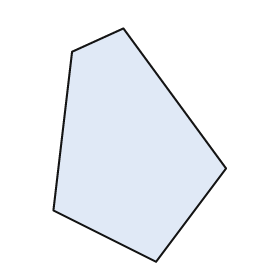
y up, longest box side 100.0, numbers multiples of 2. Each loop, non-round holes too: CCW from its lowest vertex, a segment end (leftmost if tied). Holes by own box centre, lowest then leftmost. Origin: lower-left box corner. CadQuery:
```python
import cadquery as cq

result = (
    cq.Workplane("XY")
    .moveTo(44.0, 0.0)
    .lineTo(74.0, 40.0)
    .lineTo(30.0, 100.0)
    .lineTo(8.0, 90.0)
    .lineTo(0.0, 22.0)
    .close()
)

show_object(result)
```